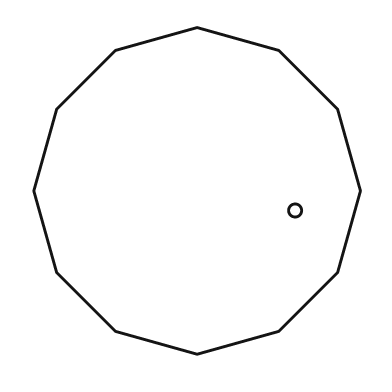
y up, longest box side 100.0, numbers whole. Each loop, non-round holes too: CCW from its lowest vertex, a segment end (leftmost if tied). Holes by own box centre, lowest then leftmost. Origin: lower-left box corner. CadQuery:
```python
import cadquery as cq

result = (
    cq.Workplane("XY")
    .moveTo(50.0, 0.0)
    .lineTo(75.0, 7.0)
    .lineTo(93.0, 25.0)
    .lineTo(100.0, 50.0)
    .lineTo(93.0, 75.0)
    .lineTo(75.0, 93.0)
    .lineTo(50.0, 100.0)
    .lineTo(25.0, 93.0)
    .lineTo(7.0, 75.0)
    .lineTo(0.0, 50.0)
    .lineTo(7.0, 25.0)
    .lineTo(25.0, 7.0)
    .close()
    .moveTo(80.0, 44.0)
    .circle(2.0)
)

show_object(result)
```